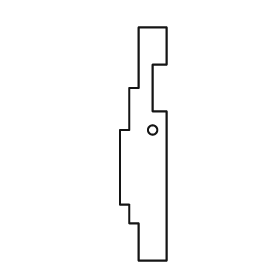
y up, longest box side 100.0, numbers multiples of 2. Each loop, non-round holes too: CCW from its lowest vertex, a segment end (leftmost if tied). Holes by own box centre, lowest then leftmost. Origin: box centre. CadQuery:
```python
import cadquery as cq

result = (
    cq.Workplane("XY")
    .moveTo(-2.0, -50.0)
    .lineTo(10.0, -50.0)
    .lineTo(10.0, 14.0)
    .lineTo(4.0, 14.0)
    .lineTo(4.0, 34.0)
    .lineTo(10.0, 34.0)
    .lineTo(10.0, 50.0)
    .lineTo(-2.0, 50.0)
    .lineTo(-2.0, 24.0)
    .lineTo(-6.0, 24.0)
    .lineTo(-6.0, 6.0)
    .lineTo(-10.0, 6.0)
    .lineTo(-10.0, -26.0)
    .lineTo(-6.0, -26.0)
    .lineTo(-6.0, -34.0)
    .lineTo(-2.0, -34.0)
    .close()
    .moveTo(4.0, 6.0)
    .circle(2.0)
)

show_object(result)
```